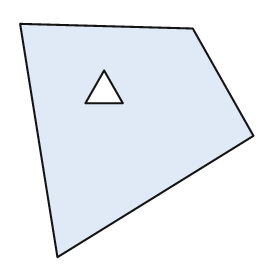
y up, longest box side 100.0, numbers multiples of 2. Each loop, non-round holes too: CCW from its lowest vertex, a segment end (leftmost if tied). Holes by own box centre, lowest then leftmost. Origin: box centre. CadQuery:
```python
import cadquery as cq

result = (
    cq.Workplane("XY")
    .moveTo(-34.0, -50.0)
    .lineTo(50.0, 2.0)
    .lineTo(24.0, 48.0)
    .lineTo(-50.0, 50.0)
    .close()
    .moveTo(-22.0, 16.0)
    .lineTo(-6.0, 16.0)
    .lineTo(-14.0, 30.0)
    .close()
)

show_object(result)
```